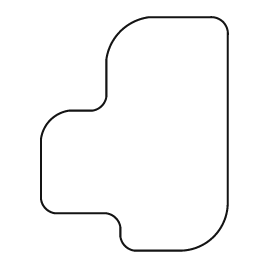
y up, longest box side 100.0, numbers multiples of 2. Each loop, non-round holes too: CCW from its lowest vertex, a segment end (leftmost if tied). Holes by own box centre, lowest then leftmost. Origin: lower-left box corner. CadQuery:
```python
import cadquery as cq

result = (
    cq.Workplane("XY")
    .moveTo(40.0, 0.0)
    .lineTo(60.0, 0.0)
    .threePointArc((74.0, 6.0), (80.0, 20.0))
    .lineTo(80.0, 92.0)
    .threePointArc((78.0, 98.0), (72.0, 100.0))
    .lineTo(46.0, 100.0)
    .threePointArc((34.0, 94.0), (28.0, 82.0))
    .lineTo(28.0, 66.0)
    .threePointArc((26.0, 62.0), (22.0, 60.0))
    .lineTo(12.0, 60.0)
    .threePointArc((4.0, 56.0), (0.0, 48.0))
    .lineTo(0.0, 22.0)
    .threePointArc((2.0, 18.0), (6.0, 16.0))
    .lineTo(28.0, 16.0)
    .threePointArc((32.0, 14.0), (34.0, 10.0))
    .lineTo(34.0, 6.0)
    .threePointArc((36.0, 2.0), (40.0, 0.0))
    .close()
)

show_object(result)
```